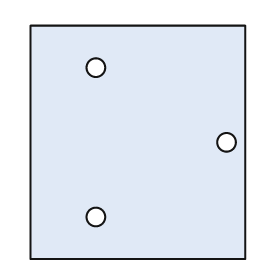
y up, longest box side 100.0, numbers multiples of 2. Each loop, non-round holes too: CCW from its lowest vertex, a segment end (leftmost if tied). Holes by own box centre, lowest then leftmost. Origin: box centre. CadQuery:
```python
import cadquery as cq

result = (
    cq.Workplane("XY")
    .moveTo(-46.0, -50.0)
    .lineTo(46.0, -50.0)
    .lineTo(46.0, 50.0)
    .lineTo(-46.0, 50.0)
    .close()
    .moveTo(-18.0, -32.0)
    .circle(4.0)
    .moveTo(38.0, 0.0)
    .circle(4.0)
    .moveTo(-18.0, 32.0)
    .circle(4.0)
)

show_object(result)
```